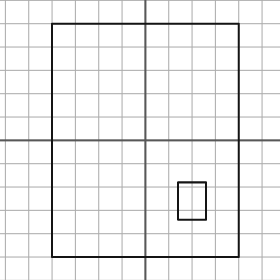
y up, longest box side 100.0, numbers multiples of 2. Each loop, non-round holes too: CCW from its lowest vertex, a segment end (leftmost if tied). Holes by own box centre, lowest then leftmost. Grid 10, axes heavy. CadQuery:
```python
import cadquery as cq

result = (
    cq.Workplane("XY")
    .moveTo(-40.0, -50.0)
    .lineTo(40.0, -50.0)
    .lineTo(40.0, 50.0)
    .lineTo(-40.0, 50.0)
    .close()
    .moveTo(14.0, -34.0)
    .lineTo(26.0, -34.0)
    .lineTo(26.0, -18.0)
    .lineTo(14.0, -18.0)
    .close()
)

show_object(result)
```